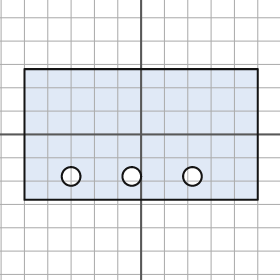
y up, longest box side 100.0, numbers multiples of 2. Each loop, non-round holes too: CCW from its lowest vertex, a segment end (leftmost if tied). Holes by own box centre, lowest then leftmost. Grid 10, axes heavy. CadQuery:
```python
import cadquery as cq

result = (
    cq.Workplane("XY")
    .moveTo(-50.0, -28.0)
    .lineTo(50.0, -28.0)
    .lineTo(50.0, 28.0)
    .lineTo(-50.0, 28.0)
    .close()
    .moveTo(-30.0, -18.0)
    .circle(4.0)
    .moveTo(-4.0, -18.0)
    .circle(4.0)
    .moveTo(22.0, -18.0)
    .circle(4.0)
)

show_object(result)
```